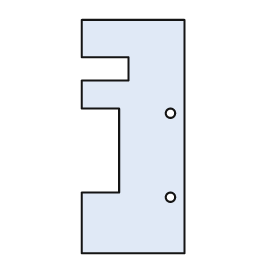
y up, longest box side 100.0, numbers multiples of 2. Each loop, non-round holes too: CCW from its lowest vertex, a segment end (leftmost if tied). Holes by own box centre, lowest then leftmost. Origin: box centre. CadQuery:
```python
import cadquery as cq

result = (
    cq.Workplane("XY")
    .moveTo(-22.0, -50.0)
    .lineTo(22.0, -50.0)
    .lineTo(22.0, 50.0)
    .lineTo(-22.0, 50.0)
    .lineTo(-22.0, 34.0)
    .lineTo(-2.0, 34.0)
    .lineTo(-2.0, 24.0)
    .lineTo(-22.0, 24.0)
    .lineTo(-22.0, 12.0)
    .lineTo(-6.0, 12.0)
    .lineTo(-6.0, -24.0)
    .lineTo(-22.0, -24.0)
    .close()
    .moveTo(16.0, -26.0)
    .circle(2.0)
    .moveTo(16.0, 10.0)
    .circle(2.0)
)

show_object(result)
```